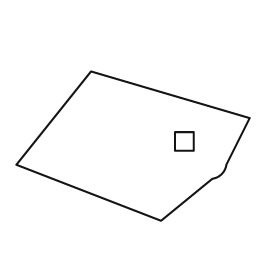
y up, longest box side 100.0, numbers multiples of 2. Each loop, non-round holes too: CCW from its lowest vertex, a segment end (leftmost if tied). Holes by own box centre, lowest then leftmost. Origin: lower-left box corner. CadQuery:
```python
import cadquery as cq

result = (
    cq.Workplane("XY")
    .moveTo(62.0, 0.0)
    .lineTo(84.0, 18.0)
    .threePointArc((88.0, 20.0), (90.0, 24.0))
    .lineTo(100.0, 44.0)
    .lineTo(32.0, 64.0)
    .lineTo(0.0, 24.0)
    .close()
    .moveTo(68.0, 30.0)
    .lineTo(76.0, 30.0)
    .lineTo(76.0, 38.0)
    .lineTo(68.0, 38.0)
    .close()
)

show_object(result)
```